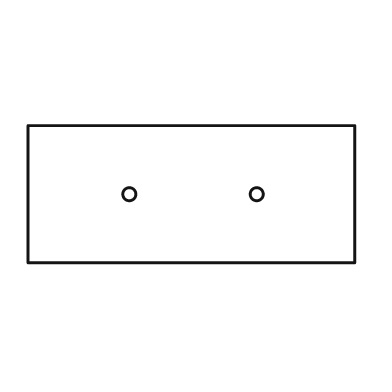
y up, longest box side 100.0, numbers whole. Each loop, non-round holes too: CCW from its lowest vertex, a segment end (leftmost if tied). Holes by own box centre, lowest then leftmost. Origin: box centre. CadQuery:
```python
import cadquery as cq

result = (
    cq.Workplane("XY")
    .moveTo(-50.0, -21.0)
    .lineTo(50.0, -21.0)
    .lineTo(50.0, 21.0)
    .lineTo(-50.0, 21.0)
    .close()
    .moveTo(-19.0, 0.0)
    .circle(2.0)
    .moveTo(20.0, 0.0)
    .circle(2.0)
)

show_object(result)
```